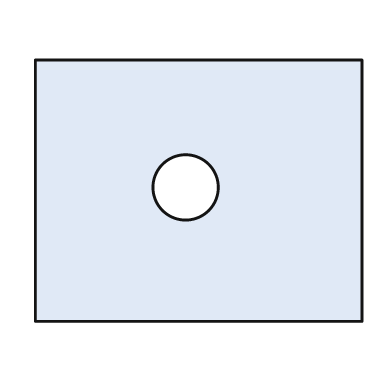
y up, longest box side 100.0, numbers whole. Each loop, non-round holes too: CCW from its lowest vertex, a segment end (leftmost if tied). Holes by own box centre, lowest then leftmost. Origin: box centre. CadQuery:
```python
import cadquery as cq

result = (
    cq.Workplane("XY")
    .moveTo(-50.0, -40.0)
    .lineTo(50.0, -40.0)
    .lineTo(50.0, 40.0)
    .lineTo(-50.0, 40.0)
    .close()
    .moveTo(-4.0, 1.0)
    .circle(10.0)
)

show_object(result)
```